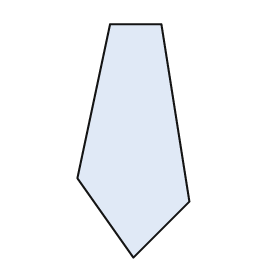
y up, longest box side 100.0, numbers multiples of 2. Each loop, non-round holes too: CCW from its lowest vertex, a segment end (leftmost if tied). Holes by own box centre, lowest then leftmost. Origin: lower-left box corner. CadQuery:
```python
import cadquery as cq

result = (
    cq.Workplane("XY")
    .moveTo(24.0, 0.0)
    .lineTo(48.0, 24.0)
    .lineTo(36.0, 100.0)
    .lineTo(14.0, 100.0)
    .lineTo(0.0, 34.0)
    .close()
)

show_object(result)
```